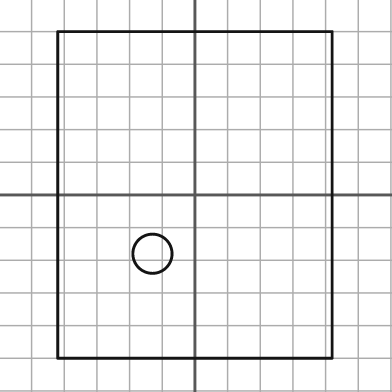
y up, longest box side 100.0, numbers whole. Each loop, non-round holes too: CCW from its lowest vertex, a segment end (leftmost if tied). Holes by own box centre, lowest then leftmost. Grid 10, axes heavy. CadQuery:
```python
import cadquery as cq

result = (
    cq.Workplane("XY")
    .moveTo(-42.0, -50.0)
    .lineTo(42.0, -50.0)
    .lineTo(42.0, 50.0)
    .lineTo(-42.0, 50.0)
    .close()
    .moveTo(-13.0, -18.0)
    .circle(6.0)
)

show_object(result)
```